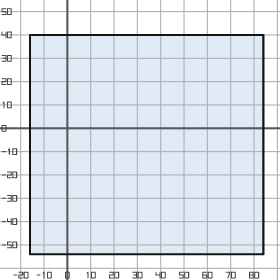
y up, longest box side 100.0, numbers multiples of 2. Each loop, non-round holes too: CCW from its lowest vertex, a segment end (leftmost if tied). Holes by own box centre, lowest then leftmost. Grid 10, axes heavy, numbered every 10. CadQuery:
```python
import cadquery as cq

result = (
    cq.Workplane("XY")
    .moveTo(-16.0, -54.0)
    .lineTo(84.0, -54.0)
    .lineTo(84.0, 40.0)
    .lineTo(-16.0, 40.0)
    .close()
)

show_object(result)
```